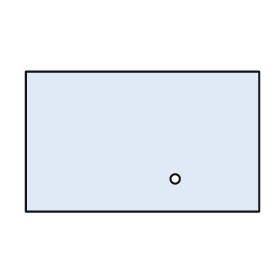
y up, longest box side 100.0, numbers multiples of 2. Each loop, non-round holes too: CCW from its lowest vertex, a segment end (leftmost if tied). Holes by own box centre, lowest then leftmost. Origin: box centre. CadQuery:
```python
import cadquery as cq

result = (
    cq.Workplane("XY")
    .moveTo(-50.0, -30.0)
    .lineTo(50.0, -30.0)
    .lineTo(50.0, 30.0)
    .lineTo(-50.0, 30.0)
    .close()
    .moveTo(14.0, -16.0)
    .circle(2.0)
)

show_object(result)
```